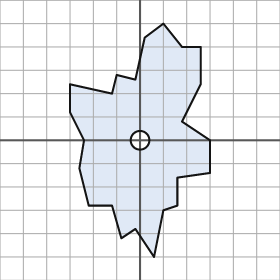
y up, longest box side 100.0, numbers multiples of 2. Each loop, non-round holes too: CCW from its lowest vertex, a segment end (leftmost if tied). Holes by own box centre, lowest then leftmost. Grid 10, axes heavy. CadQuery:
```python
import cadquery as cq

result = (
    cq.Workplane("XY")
    .moveTo(6.0, -50.0)
    .lineTo(10.0, -30.0)
    .lineTo(16.0, -28.0)
    .lineTo(16.0, -16.0)
    .lineTo(30.0, -14.0)
    .lineTo(30.0, 0.0)
    .lineTo(18.0, 8.0)
    .lineTo(26.0, 24.0)
    .lineTo(26.0, 40.0)
    .lineTo(18.0, 40.0)
    .lineTo(10.0, 50.0)
    .lineTo(2.0, 44.0)
    .lineTo(-2.0, 26.0)
    .lineTo(-10.0, 28.0)
    .lineTo(-12.0, 20.0)
    .lineTo(-30.0, 24.0)
    .lineTo(-30.0, 12.0)
    .lineTo(-24.0, 0.0)
    .lineTo(-26.0, -12.0)
    .lineTo(-22.0, -28.0)
    .lineTo(-12.0, -28.0)
    .lineTo(-8.0, -42.0)
    .lineTo(-2.0, -38.0)
    .close()
    .moveTo(0.0, 0.0)
    .circle(4.0)
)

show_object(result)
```